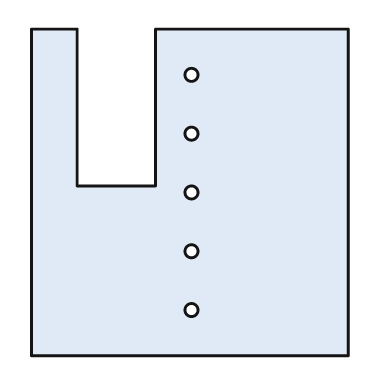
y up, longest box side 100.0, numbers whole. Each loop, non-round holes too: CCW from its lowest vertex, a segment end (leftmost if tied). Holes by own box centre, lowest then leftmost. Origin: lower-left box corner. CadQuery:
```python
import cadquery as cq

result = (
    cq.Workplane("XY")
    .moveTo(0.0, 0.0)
    .lineTo(97.0, 0.0)
    .lineTo(97.0, 100.0)
    .lineTo(38.0, 100.0)
    .lineTo(38.0, 52.0)
    .lineTo(14.0, 52.0)
    .lineTo(14.0, 100.0)
    .lineTo(0.0, 100.0)
    .close()
    .moveTo(49.0, 14.0)
    .circle(2.0)
    .moveTo(49.0, 32.0)
    .circle(2.0)
    .moveTo(49.0, 50.0)
    .circle(2.0)
    .moveTo(49.0, 68.0)
    .circle(2.0)
    .moveTo(49.0, 86.0)
    .circle(2.0)
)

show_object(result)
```